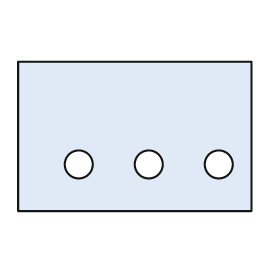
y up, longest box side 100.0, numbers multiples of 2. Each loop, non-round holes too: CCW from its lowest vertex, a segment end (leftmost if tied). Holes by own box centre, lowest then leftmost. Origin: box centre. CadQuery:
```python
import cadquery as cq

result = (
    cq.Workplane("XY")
    .moveTo(-50.0, -32.0)
    .lineTo(50.0, -32.0)
    .lineTo(50.0, 32.0)
    .lineTo(-50.0, 32.0)
    .close()
    .moveTo(-24.0, -12.0)
    .circle(6.0)
    .moveTo(6.0, -12.0)
    .circle(6.0)
    .moveTo(36.0, -12.0)
    .circle(6.0)
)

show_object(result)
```